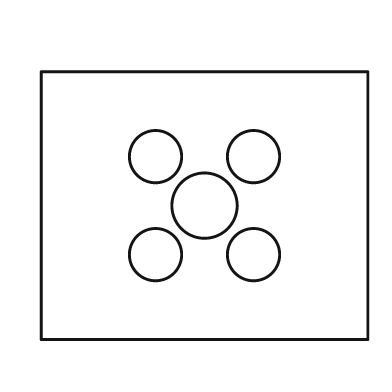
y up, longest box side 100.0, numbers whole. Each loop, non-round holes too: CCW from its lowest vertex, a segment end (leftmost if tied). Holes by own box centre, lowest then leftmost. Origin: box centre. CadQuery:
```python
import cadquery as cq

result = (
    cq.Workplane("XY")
    .moveTo(-50.0, -41.0)
    .lineTo(50.0, -41.0)
    .lineTo(50.0, 41.0)
    .lineTo(-50.0, 41.0)
    .close()
    .moveTo(-15.0, -15.0)
    .circle(8.0)
    .moveTo(15.0, -15.0)
    .circle(8.0)
    .moveTo(0.0, 0.0)
    .circle(10.0)
    .moveTo(-15.0, 15.0)
    .circle(8.0)
    .moveTo(15.0, 15.0)
    .circle(8.0)
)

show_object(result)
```